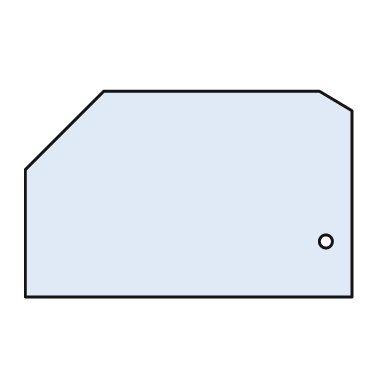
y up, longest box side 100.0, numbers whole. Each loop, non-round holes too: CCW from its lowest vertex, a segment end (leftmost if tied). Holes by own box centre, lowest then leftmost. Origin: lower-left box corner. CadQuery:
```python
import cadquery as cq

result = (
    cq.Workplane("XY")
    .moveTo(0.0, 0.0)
    .lineTo(100.0, 0.0)
    .lineTo(100.0, 57.0)
    .lineTo(90.0, 63.0)
    .lineTo(24.0, 63.0)
    .lineTo(0.0, 39.0)
    .close()
    .moveTo(92.0, 17.0)
    .circle(2.0)
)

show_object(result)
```